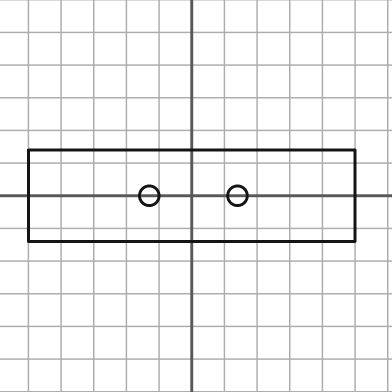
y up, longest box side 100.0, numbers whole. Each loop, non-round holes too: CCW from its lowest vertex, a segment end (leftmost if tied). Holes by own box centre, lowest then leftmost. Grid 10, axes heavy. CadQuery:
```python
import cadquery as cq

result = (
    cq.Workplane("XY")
    .moveTo(-50.0, -14.0)
    .lineTo(50.0, -14.0)
    .lineTo(50.0, 14.0)
    .lineTo(-50.0, 14.0)
    .close()
    .moveTo(-13.0, 0.0)
    .circle(3.0)
    .moveTo(14.0, 0.0)
    .circle(3.0)
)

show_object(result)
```